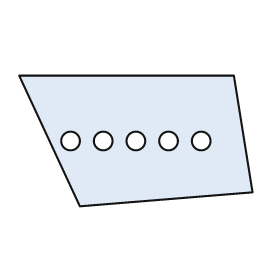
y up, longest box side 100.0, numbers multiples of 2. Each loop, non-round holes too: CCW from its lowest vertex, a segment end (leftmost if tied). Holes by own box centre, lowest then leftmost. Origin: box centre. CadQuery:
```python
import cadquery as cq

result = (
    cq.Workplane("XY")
    .moveTo(-24.0, -28.0)
    .lineTo(50.0, -22.0)
    .lineTo(42.0, 28.0)
    .lineTo(-50.0, 28.0)
    .close()
    .moveTo(-28.0, 0.0)
    .circle(4.0)
    .moveTo(-14.0, 0.0)
    .circle(4.0)
    .moveTo(0.0, 0.0)
    .circle(4.0)
    .moveTo(14.0, 0.0)
    .circle(4.0)
    .moveTo(28.0, 0.0)
    .circle(4.0)
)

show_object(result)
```